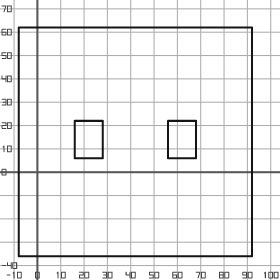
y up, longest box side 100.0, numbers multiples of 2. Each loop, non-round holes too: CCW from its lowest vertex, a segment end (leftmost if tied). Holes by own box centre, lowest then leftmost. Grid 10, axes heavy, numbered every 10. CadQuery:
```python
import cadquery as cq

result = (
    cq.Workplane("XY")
    .moveTo(-8.0, -36.0)
    .lineTo(92.0, -36.0)
    .lineTo(92.0, 62.0)
    .lineTo(-8.0, 62.0)
    .close()
    .moveTo(16.0, 6.0)
    .lineTo(28.0, 6.0)
    .lineTo(28.0, 22.0)
    .lineTo(16.0, 22.0)
    .close()
    .moveTo(56.0, 6.0)
    .lineTo(68.0, 6.0)
    .lineTo(68.0, 22.0)
    .lineTo(56.0, 22.0)
    .close()
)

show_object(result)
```